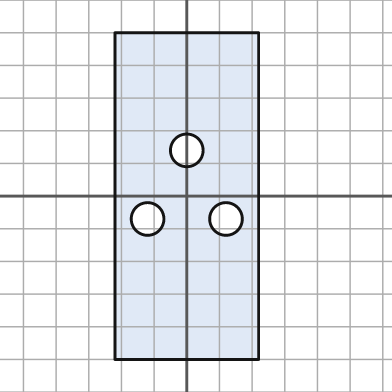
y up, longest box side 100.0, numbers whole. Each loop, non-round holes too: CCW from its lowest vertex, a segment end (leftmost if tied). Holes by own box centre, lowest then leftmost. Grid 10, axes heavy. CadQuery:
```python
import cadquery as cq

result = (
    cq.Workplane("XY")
    .moveTo(-22.0, -50.0)
    .lineTo(22.0, -50.0)
    .lineTo(22.0, 50.0)
    .lineTo(-22.0, 50.0)
    .close()
    .moveTo(-12.0, -7.0)
    .circle(5.0)
    .moveTo(12.0, -7.0)
    .circle(5.0)
    .moveTo(0.0, 14.0)
    .circle(5.0)
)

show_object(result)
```